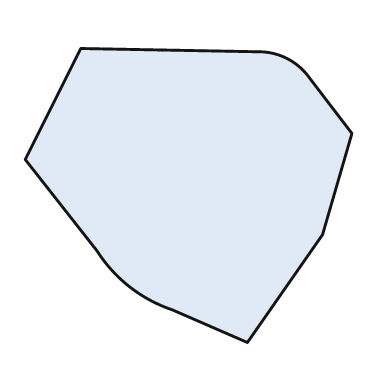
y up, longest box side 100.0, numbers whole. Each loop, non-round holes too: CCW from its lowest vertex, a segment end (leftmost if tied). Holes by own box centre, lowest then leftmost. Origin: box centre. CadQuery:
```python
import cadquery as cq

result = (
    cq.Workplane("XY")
    .moveTo(18.0, -45.0)
    .lineTo(41.0, -12.0)
    .lineTo(50.0, 19.0)
    .lineTo(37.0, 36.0)
    .threePointArc((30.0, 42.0), (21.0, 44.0))
    .lineTo(-33.0, 45.0)
    .lineTo(-50.0, 11.0)
    .lineTo(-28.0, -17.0)
    .threePointArc((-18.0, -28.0), (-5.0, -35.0))
    .close()
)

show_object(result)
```